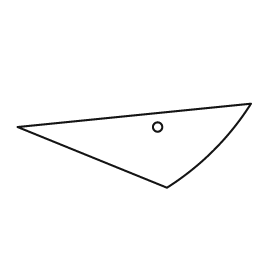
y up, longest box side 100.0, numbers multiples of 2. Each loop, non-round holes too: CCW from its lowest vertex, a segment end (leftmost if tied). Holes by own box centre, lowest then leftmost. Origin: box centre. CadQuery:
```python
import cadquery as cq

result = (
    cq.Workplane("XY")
    .moveTo(14.0, -18.0)
    .threePointArc((34.0, -2.0), (50.0, 18.0))
    .lineTo(-50.0, 8.0)
    .close()
    .moveTo(10.0, 8.0)
    .circle(2.0)
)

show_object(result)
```